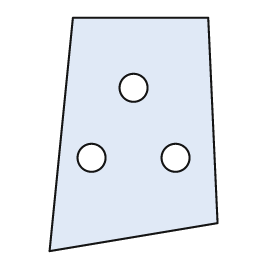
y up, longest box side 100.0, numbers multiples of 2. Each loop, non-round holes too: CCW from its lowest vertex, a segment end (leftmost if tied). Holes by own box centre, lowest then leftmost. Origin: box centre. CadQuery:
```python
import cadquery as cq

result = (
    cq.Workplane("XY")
    .moveTo(-36.0, -50.0)
    .lineTo(36.0, -38.0)
    .lineTo(32.0, 50.0)
    .lineTo(-26.0, 50.0)
    .close()
    .moveTo(-18.0, -10.0)
    .circle(6.0)
    .moveTo(18.0, -10.0)
    .circle(6.0)
    .moveTo(0.0, 20.0)
    .circle(6.0)
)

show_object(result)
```